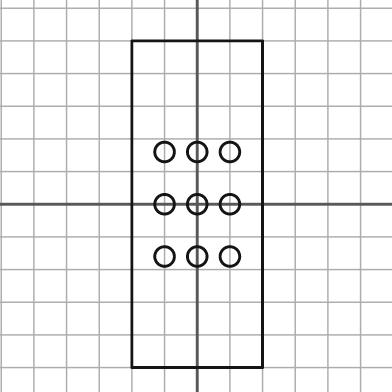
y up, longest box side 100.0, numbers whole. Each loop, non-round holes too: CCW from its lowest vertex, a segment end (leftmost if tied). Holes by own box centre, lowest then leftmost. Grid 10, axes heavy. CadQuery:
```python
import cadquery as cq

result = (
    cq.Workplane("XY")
    .moveTo(-20.0, -50.0)
    .lineTo(20.0, -50.0)
    .lineTo(20.0, 50.0)
    .lineTo(-20.0, 50.0)
    .close()
    .moveTo(-10.0, -16.0)
    .circle(3.0)
    .moveTo(0.0, -16.0)
    .circle(3.0)
    .moveTo(10.0, -16.0)
    .circle(3.0)
    .moveTo(-10.0, 0.0)
    .circle(3.0)
    .moveTo(0.0, 0.0)
    .circle(3.0)
    .moveTo(10.0, 0.0)
    .circle(3.0)
    .moveTo(-10.0, 16.0)
    .circle(3.0)
    .moveTo(0.0, 16.0)
    .circle(3.0)
    .moveTo(10.0, 16.0)
    .circle(3.0)
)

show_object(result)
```